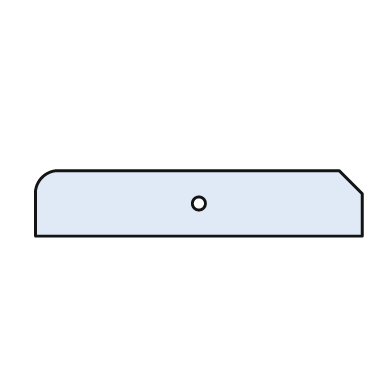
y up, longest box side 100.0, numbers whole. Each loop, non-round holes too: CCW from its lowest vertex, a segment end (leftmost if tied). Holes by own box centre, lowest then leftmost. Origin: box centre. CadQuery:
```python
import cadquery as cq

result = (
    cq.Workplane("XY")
    .moveTo(-50.0, -10.0)
    .lineTo(50.0, -10.0)
    .lineTo(50.0, 3.0)
    .lineTo(43.0, 10.0)
    .lineTo(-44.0, 10.0)
    .threePointArc((-48.0, 8.0), (-50.0, 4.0))
    .close()
    .moveTo(0.0, 0.0)
    .circle(2.0)
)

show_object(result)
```